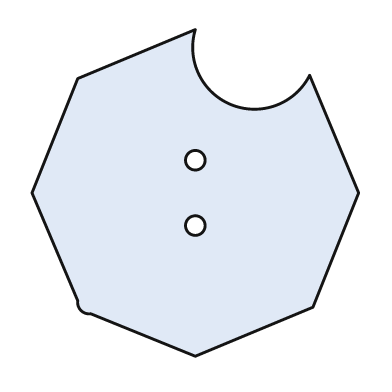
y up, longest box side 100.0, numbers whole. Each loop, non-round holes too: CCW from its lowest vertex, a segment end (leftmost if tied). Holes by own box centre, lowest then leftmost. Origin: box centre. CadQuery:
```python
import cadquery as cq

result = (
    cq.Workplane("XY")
    .moveTo(0.0, -50.0)
    .lineTo(36.0, -35.0)
    .lineTo(50.0, 0.0)
    .lineTo(35.0, 36.0)
    .threePointArc((11.0, 27.0), (0.0, 50.0))
    .lineTo(-36.0, 35.0)
    .lineTo(-50.0, 0.0)
    .lineTo(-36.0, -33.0)
    .threePointArc((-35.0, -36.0), (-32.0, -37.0))
    .close()
    .moveTo(0.0, -10.0)
    .circle(3.0)
    .moveTo(0.0, 10.0)
    .circle(3.0)
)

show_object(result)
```